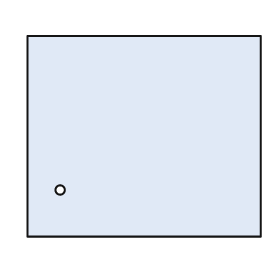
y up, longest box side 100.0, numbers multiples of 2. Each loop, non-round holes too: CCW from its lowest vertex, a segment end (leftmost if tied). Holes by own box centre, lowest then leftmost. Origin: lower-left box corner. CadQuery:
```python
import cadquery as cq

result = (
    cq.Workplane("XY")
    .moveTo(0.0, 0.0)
    .lineTo(100.0, 0.0)
    .lineTo(100.0, 86.0)
    .lineTo(0.0, 86.0)
    .close()
    .moveTo(14.0, 20.0)
    .circle(2.0)
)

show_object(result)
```